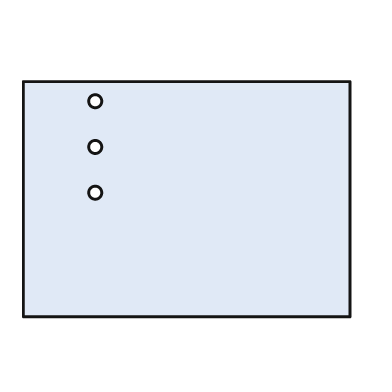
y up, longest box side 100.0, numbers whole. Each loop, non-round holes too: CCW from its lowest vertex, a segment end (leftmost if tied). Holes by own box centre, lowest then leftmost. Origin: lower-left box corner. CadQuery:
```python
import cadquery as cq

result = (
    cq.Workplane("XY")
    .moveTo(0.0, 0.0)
    .lineTo(100.0, 0.0)
    .lineTo(100.0, 72.0)
    .lineTo(0.0, 72.0)
    .close()
    .moveTo(22.0, 38.0)
    .circle(2.0)
    .moveTo(22.0, 52.0)
    .circle(2.0)
    .moveTo(22.0, 66.0)
    .circle(2.0)
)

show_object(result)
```